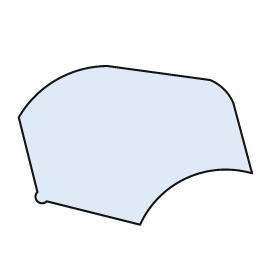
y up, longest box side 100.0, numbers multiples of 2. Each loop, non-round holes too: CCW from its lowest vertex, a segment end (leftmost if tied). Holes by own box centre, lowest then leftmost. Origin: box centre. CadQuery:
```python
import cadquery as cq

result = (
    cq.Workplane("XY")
    .moveTo(2.0, -34.0)
    .threePointArc((22.0, -14.0), (50.0, -12.0))
    .lineTo(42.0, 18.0)
    .threePointArc((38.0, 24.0), (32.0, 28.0))
    .lineTo(-12.0, 34.0)
    .threePointArc((-34.0, 28.0), (-50.0, 12.0))
    .lineTo(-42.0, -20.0)
    .threePointArc((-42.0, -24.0), (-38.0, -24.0))
    .close()
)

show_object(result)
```